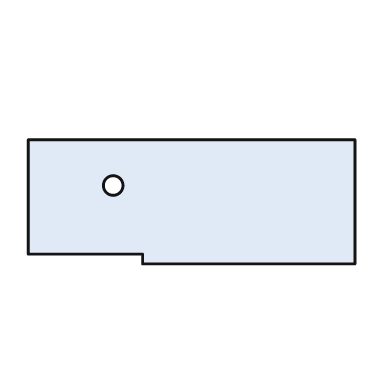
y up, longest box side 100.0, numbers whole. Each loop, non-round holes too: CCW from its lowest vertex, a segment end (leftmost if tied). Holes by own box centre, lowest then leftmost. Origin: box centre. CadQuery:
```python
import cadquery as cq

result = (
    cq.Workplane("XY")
    .moveTo(-15.0, -19.0)
    .lineTo(50.0, -19.0)
    .lineTo(50.0, 19.0)
    .lineTo(-50.0, 19.0)
    .lineTo(-50.0, -16.0)
    .lineTo(-15.0, -16.0)
    .close()
    .moveTo(-24.0, 5.0)
    .circle(3.0)
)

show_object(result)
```